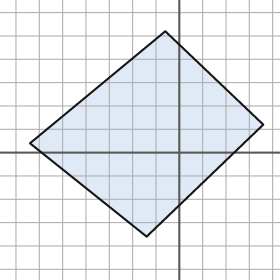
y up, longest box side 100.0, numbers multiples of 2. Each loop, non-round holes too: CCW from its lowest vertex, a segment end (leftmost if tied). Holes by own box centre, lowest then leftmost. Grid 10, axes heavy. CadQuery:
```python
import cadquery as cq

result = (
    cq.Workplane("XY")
    .moveTo(-14.0, -36.0)
    .lineTo(36.0, 12.0)
    .lineTo(-6.0, 52.0)
    .lineTo(-64.0, 4.0)
    .close()
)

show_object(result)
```